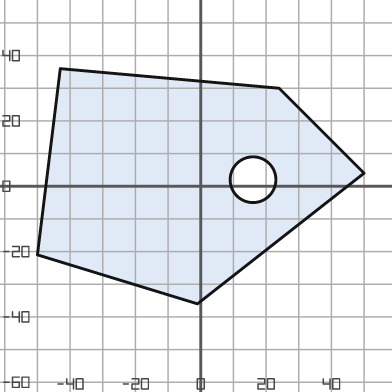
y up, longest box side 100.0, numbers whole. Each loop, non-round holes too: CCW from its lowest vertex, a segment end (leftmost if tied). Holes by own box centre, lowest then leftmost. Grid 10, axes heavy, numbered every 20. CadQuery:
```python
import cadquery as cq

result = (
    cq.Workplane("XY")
    .moveTo(-1.0, -36.0)
    .lineTo(50.0, 4.0)
    .lineTo(24.0, 30.0)
    .lineTo(-43.0, 36.0)
    .lineTo(-50.0, -21.0)
    .close()
    .moveTo(16.0, 2.0)
    .circle(7.0)
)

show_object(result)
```